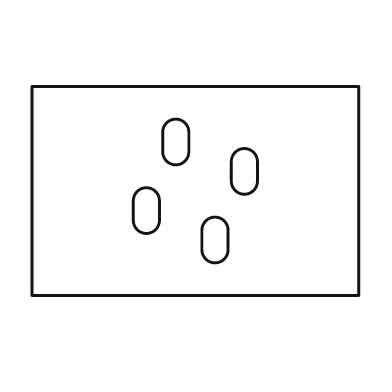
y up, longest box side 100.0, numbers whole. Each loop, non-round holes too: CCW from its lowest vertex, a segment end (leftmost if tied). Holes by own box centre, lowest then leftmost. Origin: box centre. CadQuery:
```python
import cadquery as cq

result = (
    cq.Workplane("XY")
    .moveTo(-50.0, -32.0)
    .lineTo(50.0, -32.0)
    .lineTo(50.0, 32.0)
    .lineTo(-50.0, 32.0)
    .close()
    .moveTo(2.0, -18.0)
    .threePointArc((6.0, -22.0), (10.0, -18.0))
    .lineTo(10.0, -12.0)
    .threePointArc((6.0, -8.0), (2.0, -12.0))
    .close()
    .moveTo(-19.0, -9.0)
    .threePointArc((-15.0, -13.0), (-11.0, -9.0))
    .lineTo(-11.0, -3.0)
    .threePointArc((-15.0, 1.0), (-19.0, -3.0))
    .close()
    .moveTo(11.0, 3.0)
    .threePointArc((15.0, -1.0), (19.0, 3.0))
    .lineTo(19.0, 9.0)
    .threePointArc((15.0, 13.0), (11.0, 9.0))
    .close()
    .moveTo(-10.0, 12.0)
    .threePointArc((-6.0, 8.0), (-2.0, 12.0))
    .lineTo(-2.0, 18.0)
    .threePointArc((-6.0, 22.0), (-10.0, 18.0))
    .close()
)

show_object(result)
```